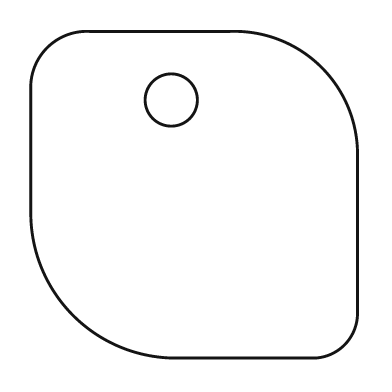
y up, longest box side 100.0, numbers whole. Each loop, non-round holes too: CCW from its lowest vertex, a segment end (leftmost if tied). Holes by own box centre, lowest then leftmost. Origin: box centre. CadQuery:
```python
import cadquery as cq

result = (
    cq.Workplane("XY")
    .moveTo(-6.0, -50.0)
    .lineTo(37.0, -50.0)
    .threePointArc((46.0, -46.0), (50.0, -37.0))
    .lineTo(50.0, 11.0)
    .threePointArc((39.0, 39.0), (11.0, 50.0))
    .lineTo(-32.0, 50.0)
    .threePointArc((-45.0, 45.0), (-50.0, 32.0))
    .lineTo(-50.0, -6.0)
    .threePointArc((-37.0, -37.0), (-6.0, -50.0))
    .close()
    .moveTo(-7.0, 29.0)
    .circle(8.0)
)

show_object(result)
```